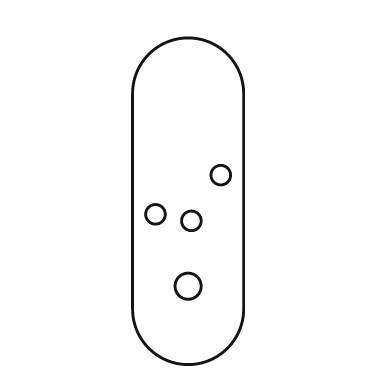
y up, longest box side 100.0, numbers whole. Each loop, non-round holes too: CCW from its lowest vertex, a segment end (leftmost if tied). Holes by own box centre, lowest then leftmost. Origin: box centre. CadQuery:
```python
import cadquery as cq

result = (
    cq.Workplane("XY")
    .moveTo(-17.0, -33.0)
    .threePointArc((0.0, -50.0), (17.0, -33.0))
    .lineTo(17.0, 33.0)
    .threePointArc((0.0, 50.0), (-17.0, 33.0))
    .close()
    .moveTo(0.0, -26.0)
    .circle(4.0)
    .moveTo(1.0, -6.0)
    .circle(3.0)
    .moveTo(-10.0, -4.0)
    .circle(3.0)
    .moveTo(10.0, 8.0)
    .circle(3.0)
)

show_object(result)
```